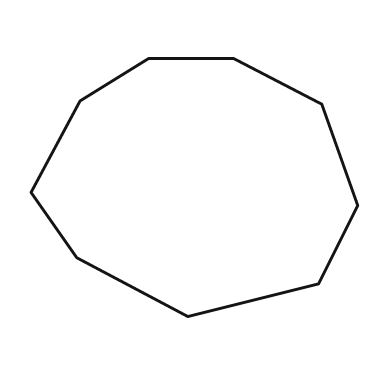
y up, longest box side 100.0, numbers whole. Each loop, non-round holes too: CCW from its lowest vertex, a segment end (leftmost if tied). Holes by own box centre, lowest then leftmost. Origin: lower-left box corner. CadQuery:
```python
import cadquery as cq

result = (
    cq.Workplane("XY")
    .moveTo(48.0, 0.0)
    .lineTo(88.0, 10.0)
    .lineTo(100.0, 34.0)
    .lineTo(89.0, 65.0)
    .lineTo(62.0, 79.0)
    .lineTo(36.0, 79.0)
    .lineTo(15.0, 66.0)
    .lineTo(0.0, 38.0)
    .lineTo(14.0, 18.0)
    .close()
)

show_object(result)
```